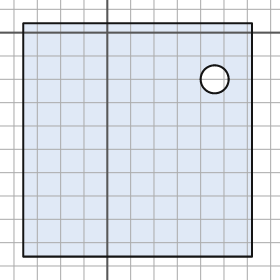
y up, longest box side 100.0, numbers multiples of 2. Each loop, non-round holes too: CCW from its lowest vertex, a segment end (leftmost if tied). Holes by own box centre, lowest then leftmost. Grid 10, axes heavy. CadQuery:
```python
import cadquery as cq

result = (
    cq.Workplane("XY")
    .moveTo(-36.0, -96.0)
    .lineTo(62.0, -96.0)
    .lineTo(62.0, 4.0)
    .lineTo(-36.0, 4.0)
    .close()
    .moveTo(46.0, -20.0)
    .circle(6.0)
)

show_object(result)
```